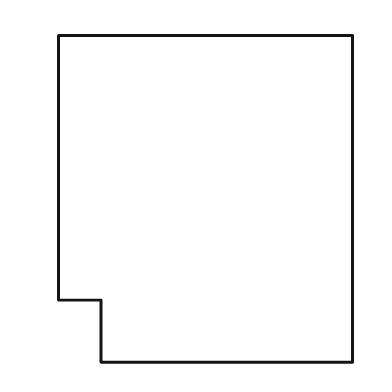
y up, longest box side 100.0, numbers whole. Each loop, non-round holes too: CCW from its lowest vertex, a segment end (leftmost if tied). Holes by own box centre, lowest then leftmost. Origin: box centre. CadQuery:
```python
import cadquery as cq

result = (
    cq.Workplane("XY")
    .moveTo(-32.0, -50.0)
    .lineTo(45.0, -50.0)
    .lineTo(45.0, 50.0)
    .lineTo(-45.0, 50.0)
    .lineTo(-45.0, -31.0)
    .lineTo(-32.0, -31.0)
    .close()
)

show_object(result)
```